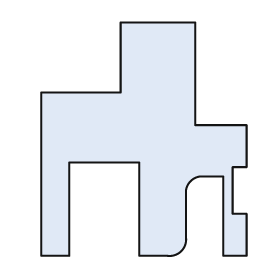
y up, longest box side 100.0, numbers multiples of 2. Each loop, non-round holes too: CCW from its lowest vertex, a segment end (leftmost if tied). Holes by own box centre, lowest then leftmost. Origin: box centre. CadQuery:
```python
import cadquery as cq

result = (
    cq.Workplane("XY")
    .moveTo(-44.0, -50.0)
    .lineTo(-32.0, -50.0)
    .lineTo(-32.0, -10.0)
    .lineTo(-2.0, -10.0)
    .lineTo(-2.0, -50.0)
    .lineTo(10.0, -50.0)
    .threePointArc((16.0, -48.0), (18.0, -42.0))
    .lineTo(18.0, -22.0)
    .threePointArc((20.0, -18.0), (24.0, -16.0))
    .lineTo(34.0, -16.0)
    .lineTo(34.0, -50.0)
    .lineTo(44.0, -50.0)
    .lineTo(44.0, -32.0)
    .lineTo(38.0, -32.0)
    .lineTo(38.0, -12.0)
    .lineTo(44.0, -12.0)
    .lineTo(44.0, 6.0)
    .lineTo(22.0, 6.0)
    .lineTo(22.0, 50.0)
    .lineTo(-10.0, 50.0)
    .lineTo(-10.0, 20.0)
    .lineTo(-44.0, 20.0)
    .close()
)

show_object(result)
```